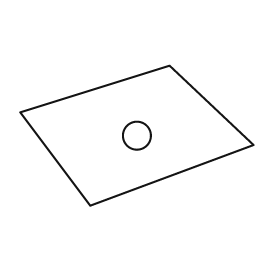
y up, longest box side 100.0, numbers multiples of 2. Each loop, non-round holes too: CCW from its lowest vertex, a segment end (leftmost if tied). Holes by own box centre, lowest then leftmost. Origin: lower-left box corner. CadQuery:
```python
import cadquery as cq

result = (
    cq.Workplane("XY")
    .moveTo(30.0, 0.0)
    .lineTo(100.0, 26.0)
    .lineTo(64.0, 60.0)
    .lineTo(0.0, 40.0)
    .close()
    .moveTo(50.0, 30.0)
    .circle(6.0)
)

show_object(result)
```